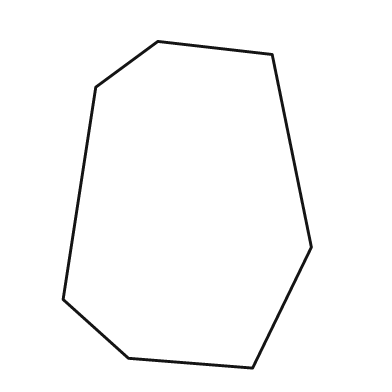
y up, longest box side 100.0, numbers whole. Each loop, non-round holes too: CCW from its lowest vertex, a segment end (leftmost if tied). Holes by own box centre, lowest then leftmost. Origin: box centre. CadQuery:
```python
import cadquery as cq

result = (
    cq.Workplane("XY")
    .moveTo(20.0, -50.0)
    .lineTo(38.0, -13.0)
    .lineTo(26.0, 46.0)
    .lineTo(-9.0, 50.0)
    .lineTo(-28.0, 36.0)
    .lineTo(-38.0, -29.0)
    .lineTo(-18.0, -47.0)
    .close()
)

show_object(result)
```